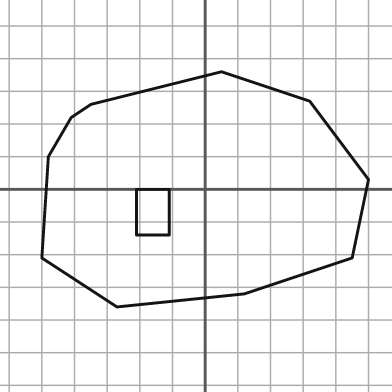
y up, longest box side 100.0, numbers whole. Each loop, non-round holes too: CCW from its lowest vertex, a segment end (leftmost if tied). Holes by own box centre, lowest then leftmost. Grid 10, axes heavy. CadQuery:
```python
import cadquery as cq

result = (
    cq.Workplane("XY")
    .moveTo(-27.0, -36.0)
    .lineTo(12.0, -32.0)
    .lineTo(45.0, -21.0)
    .lineTo(50.0, 3.0)
    .lineTo(32.0, 27.0)
    .lineTo(5.0, 36.0)
    .lineTo(-35.0, 26.0)
    .lineTo(-41.0, 22.0)
    .lineTo(-48.0, 10.0)
    .lineTo(-50.0, -21.0)
    .close()
    .moveTo(-21.0, -14.0)
    .lineTo(-11.0, -14.0)
    .lineTo(-11.0, 0.0)
    .lineTo(-21.0, 0.0)
    .close()
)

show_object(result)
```